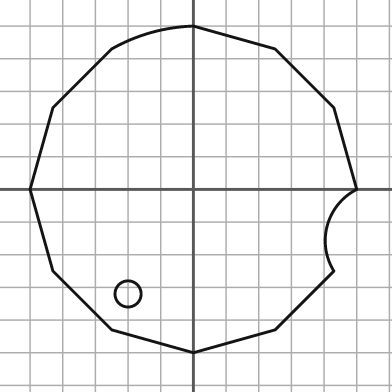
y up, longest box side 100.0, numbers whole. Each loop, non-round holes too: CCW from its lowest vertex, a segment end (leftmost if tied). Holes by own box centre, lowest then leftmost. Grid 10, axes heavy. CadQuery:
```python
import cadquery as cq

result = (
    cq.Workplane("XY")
    .moveTo(0.0, -50.0)
    .lineTo(25.0, -43.0)
    .lineTo(43.0, -25.0)
    .threePointArc((41.0, -11.0), (50.0, 0.0))
    .lineTo(43.0, 25.0)
    .lineTo(25.0, 43.0)
    .lineTo(0.0, 50.0)
    .threePointArc((-13.0, 48.0), (-25.0, 43.0))
    .lineTo(-43.0, 25.0)
    .lineTo(-50.0, 0.0)
    .lineTo(-43.0, -25.0)
    .lineTo(-25.0, -43.0)
    .close()
    .moveTo(-20.0, -32.0)
    .circle(4.0)
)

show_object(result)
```